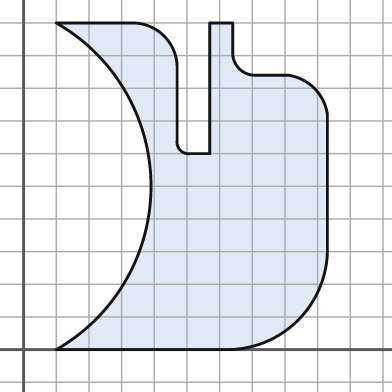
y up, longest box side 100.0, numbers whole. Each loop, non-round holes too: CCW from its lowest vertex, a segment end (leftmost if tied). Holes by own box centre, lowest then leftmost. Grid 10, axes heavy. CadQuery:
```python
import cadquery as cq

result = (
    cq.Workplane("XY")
    .moveTo(10.0, 0.0)
    .lineTo(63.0, 0.0)
    .threePointArc((84.0, 9.0), (93.0, 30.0))
    .lineTo(93.0, 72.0)
    .threePointArc((89.0, 80.0), (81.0, 84.0))
    .lineTo(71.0, 84.0)
    .threePointArc((66.0, 86.0), (64.0, 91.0))
    .lineTo(64.0, 100.0)
    .lineTo(57.0, 100.0)
    .lineTo(57.0, 60.0)
    .lineTo(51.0, 60.0)
    .threePointArc((48.0, 61.0), (47.0, 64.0))
    .lineTo(47.0, 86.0)
    .threePointArc((43.0, 96.0), (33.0, 100.0))
    .lineTo(10.0, 100.0)
    .threePointArc((39.0, 50.0), (10.0, 0.0))
    .close()
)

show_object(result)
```